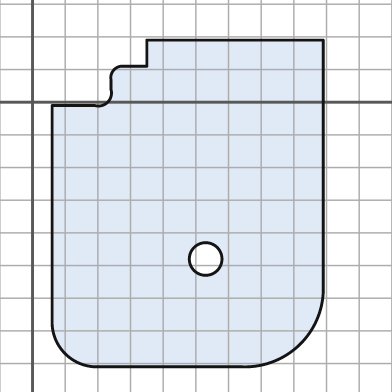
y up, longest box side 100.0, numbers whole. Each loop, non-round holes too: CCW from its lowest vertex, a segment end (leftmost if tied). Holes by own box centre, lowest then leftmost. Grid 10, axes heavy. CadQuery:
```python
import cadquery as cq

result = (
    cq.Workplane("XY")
    .moveTo(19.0, -81.0)
    .lineTo(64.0, -81.0)
    .threePointArc((82.0, -74.0), (89.0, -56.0))
    .lineTo(89.0, 19.0)
    .lineTo(35.0, 19.0)
    .lineTo(35.0, 11.0)
    .lineTo(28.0, 11.0)
    .threePointArc((25.0, 10.0), (24.0, 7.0))
    .lineTo(24.0, 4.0)
    .threePointArc((23.0, 0.0), (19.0, -1.0))
    .lineTo(6.0, -1.0)
    .lineTo(6.0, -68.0)
    .threePointArc((10.0, -77.0), (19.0, -81.0))
    .close()
    .moveTo(53.0, -48.0)
    .circle(5.0)
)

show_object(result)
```